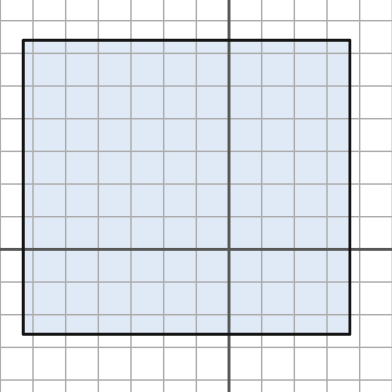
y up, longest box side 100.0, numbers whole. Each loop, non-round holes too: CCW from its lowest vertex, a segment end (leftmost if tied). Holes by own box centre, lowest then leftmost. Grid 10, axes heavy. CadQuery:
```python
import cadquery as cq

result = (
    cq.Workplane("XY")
    .moveTo(-63.0, -26.0)
    .lineTo(37.0, -26.0)
    .lineTo(37.0, 64.0)
    .lineTo(-63.0, 64.0)
    .close()
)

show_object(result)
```